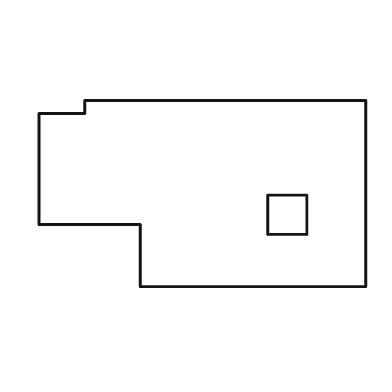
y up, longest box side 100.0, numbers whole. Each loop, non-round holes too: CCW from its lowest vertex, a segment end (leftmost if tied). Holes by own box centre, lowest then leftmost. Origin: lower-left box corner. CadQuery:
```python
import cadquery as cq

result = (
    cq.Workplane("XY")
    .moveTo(31.0, 0.0)
    .lineTo(100.0, 0.0)
    .lineTo(100.0, 57.0)
    .lineTo(14.0, 57.0)
    .lineTo(14.0, 53.0)
    .lineTo(0.0, 53.0)
    .lineTo(0.0, 19.0)
    .lineTo(31.0, 19.0)
    .close()
    .moveTo(70.0, 16.0)
    .lineTo(82.0, 16.0)
    .lineTo(82.0, 28.0)
    .lineTo(70.0, 28.0)
    .close()
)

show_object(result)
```